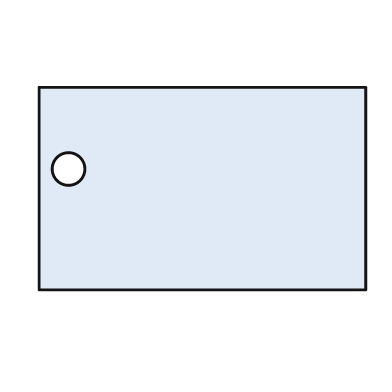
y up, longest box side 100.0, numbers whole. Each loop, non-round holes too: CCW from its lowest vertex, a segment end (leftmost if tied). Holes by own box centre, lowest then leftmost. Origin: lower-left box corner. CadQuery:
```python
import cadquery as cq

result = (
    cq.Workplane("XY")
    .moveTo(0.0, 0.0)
    .lineTo(100.0, 0.0)
    .lineTo(100.0, 62.0)
    .lineTo(0.0, 62.0)
    .close()
    .moveTo(9.0, 37.0)
    .circle(5.0)
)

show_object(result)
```